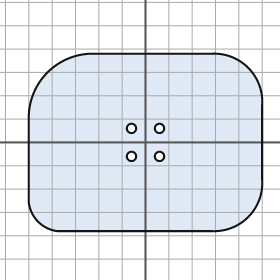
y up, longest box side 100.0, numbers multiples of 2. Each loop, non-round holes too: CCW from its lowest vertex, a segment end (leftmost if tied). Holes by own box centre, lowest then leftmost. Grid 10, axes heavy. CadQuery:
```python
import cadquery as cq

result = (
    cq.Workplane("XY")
    .moveTo(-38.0, -38.0)
    .lineTo(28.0, -38.0)
    .threePointArc((44.0, -32.0), (50.0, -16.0))
    .lineTo(50.0, 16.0)
    .threePointArc((44.0, 32.0), (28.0, 38.0))
    .lineTo(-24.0, 38.0)
    .threePointArc((-42.0, 30.0), (-50.0, 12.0))
    .lineTo(-50.0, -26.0)
    .threePointArc((-46.0, -34.0), (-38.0, -38.0))
    .close()
    .moveTo(-6.0, -6.0)
    .circle(2.0)
    .moveTo(6.0, -6.0)
    .circle(2.0)
    .moveTo(-6.0, 6.0)
    .circle(2.0)
    .moveTo(6.0, 6.0)
    .circle(2.0)
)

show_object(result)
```